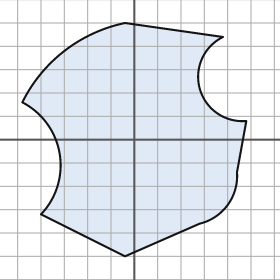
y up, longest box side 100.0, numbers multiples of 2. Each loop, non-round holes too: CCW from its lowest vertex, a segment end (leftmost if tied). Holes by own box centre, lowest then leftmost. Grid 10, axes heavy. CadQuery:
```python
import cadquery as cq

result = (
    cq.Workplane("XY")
    .moveTo(-4.0, -50.0)
    .lineTo(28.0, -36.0)
    .threePointArc((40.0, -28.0), (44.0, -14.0))
    .lineTo(48.0, 8.0)
    .threePointArc((28.0, 22.0), (38.0, 44.0))
    .lineTo(-4.0, 50.0)
    .threePointArc((-30.0, 38.0), (-48.0, 16.0))
    .threePointArc((-32.0, -6.0), (-40.0, -32.0))
    .close()
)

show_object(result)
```